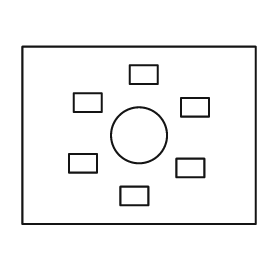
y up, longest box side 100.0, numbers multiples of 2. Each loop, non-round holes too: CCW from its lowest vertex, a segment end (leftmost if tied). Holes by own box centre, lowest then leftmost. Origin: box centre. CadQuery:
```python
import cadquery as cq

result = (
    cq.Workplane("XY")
    .moveTo(-50.0, -38.0)
    .lineTo(50.0, -38.0)
    .lineTo(50.0, 38.0)
    .lineTo(-50.0, 38.0)
    .close()
    .moveTo(-8.0, -30.0)
    .lineTo(4.0, -30.0)
    .lineTo(4.0, -22.0)
    .lineTo(-8.0, -22.0)
    .close()
    .moveTo(16.0, -18.0)
    .lineTo(28.0, -18.0)
    .lineTo(28.0, -10.0)
    .lineTo(16.0, -10.0)
    .close()
    .moveTo(-30.0, -16.0)
    .lineTo(-18.0, -16.0)
    .lineTo(-18.0, -8.0)
    .lineTo(-30.0, -8.0)
    .close()
    .moveTo(0.0, 0.0)
    .circle(12.0)
    .moveTo(18.0, 8.0)
    .lineTo(30.0, 8.0)
    .lineTo(30.0, 16.0)
    .lineTo(18.0, 16.0)
    .close()
    .moveTo(-28.0, 10.0)
    .lineTo(-16.0, 10.0)
    .lineTo(-16.0, 18.0)
    .lineTo(-28.0, 18.0)
    .close()
    .moveTo(-4.0, 22.0)
    .lineTo(8.0, 22.0)
    .lineTo(8.0, 30.0)
    .lineTo(-4.0, 30.0)
    .close()
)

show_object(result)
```